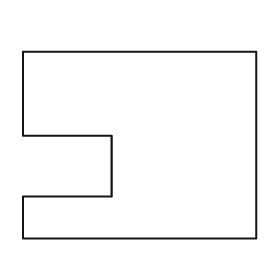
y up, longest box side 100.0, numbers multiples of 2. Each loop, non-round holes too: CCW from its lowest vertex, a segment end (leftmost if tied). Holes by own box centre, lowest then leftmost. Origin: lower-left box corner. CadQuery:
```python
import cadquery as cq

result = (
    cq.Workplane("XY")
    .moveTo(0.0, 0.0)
    .lineTo(100.0, 0.0)
    .lineTo(100.0, 80.0)
    .lineTo(0.0, 80.0)
    .lineTo(0.0, 44.0)
    .lineTo(38.0, 44.0)
    .lineTo(38.0, 18.0)
    .lineTo(0.0, 18.0)
    .close()
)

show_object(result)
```